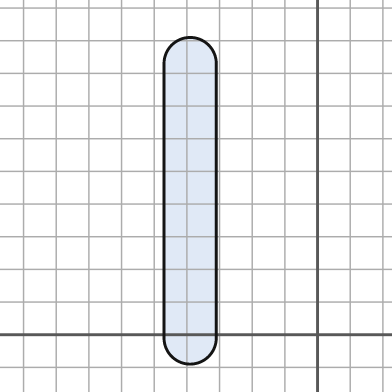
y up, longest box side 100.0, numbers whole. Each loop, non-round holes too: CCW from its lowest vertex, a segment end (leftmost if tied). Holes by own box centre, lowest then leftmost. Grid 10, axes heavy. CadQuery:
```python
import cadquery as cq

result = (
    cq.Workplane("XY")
    .moveTo(-47.0, -1.0)
    .threePointArc((-39.0, -9.0), (-31.0, -1.0))
    .lineTo(-31.0, 83.0)
    .threePointArc((-39.0, 91.0), (-47.0, 83.0))
    .close()
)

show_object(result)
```